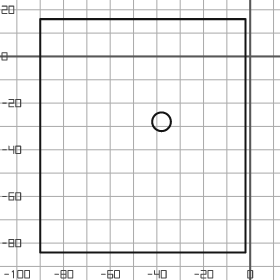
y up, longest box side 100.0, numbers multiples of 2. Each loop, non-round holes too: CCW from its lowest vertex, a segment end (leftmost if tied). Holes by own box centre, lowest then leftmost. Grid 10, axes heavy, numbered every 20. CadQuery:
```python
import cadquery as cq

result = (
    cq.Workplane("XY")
    .moveTo(-90.0, -84.0)
    .lineTo(-2.0, -84.0)
    .lineTo(-2.0, 16.0)
    .lineTo(-90.0, 16.0)
    .close()
    .moveTo(-38.0, -28.0)
    .circle(4.0)
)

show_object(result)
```